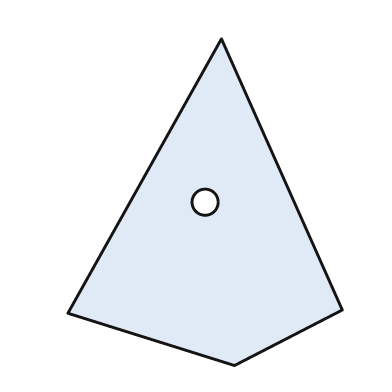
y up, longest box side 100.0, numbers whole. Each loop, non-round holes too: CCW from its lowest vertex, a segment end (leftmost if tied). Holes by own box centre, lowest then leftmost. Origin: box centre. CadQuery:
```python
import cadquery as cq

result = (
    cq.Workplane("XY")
    .moveTo(9.0, -50.0)
    .lineTo(42.0, -33.0)
    .lineTo(5.0, 50.0)
    .lineTo(-42.0, -34.0)
    .close()
    .moveTo(0.0, 0.0)
    .circle(4.0)
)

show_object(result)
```